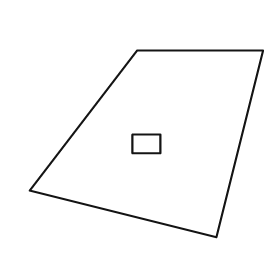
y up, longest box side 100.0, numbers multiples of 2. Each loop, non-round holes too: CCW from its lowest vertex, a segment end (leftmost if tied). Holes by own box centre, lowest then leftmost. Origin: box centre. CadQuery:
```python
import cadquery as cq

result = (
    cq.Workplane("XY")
    .moveTo(30.0, -40.0)
    .lineTo(50.0, 40.0)
    .lineTo(-4.0, 40.0)
    .lineTo(-50.0, -20.0)
    .close()
    .moveTo(-6.0, -4.0)
    .lineTo(6.0, -4.0)
    .lineTo(6.0, 4.0)
    .lineTo(-6.0, 4.0)
    .close()
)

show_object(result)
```